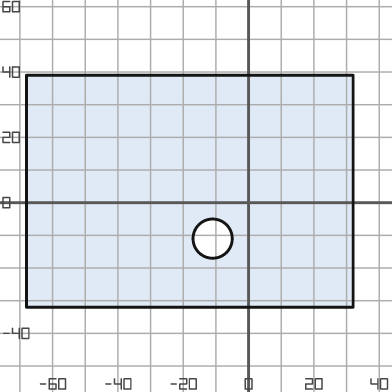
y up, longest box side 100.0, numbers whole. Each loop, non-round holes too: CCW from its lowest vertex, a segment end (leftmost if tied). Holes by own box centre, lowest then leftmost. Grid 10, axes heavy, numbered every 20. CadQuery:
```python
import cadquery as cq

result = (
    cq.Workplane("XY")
    .moveTo(-68.0, -32.0)
    .lineTo(32.0, -32.0)
    .lineTo(32.0, 39.0)
    .lineTo(-68.0, 39.0)
    .close()
    .moveTo(-11.0, -11.0)
    .circle(6.0)
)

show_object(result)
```